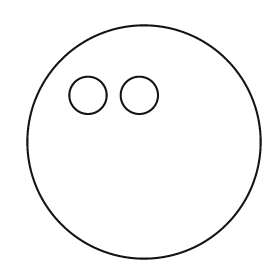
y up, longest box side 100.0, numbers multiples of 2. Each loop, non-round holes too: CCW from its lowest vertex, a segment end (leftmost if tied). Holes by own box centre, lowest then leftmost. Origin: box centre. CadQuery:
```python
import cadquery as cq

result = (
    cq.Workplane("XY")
    .moveTo(0.0, 0.0)
    .circle(50.0)
    .moveTo(-24.0, 20.0)
    .circle(8.0)
    .moveTo(-2.0, 20.0)
    .circle(8.0)
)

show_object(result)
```